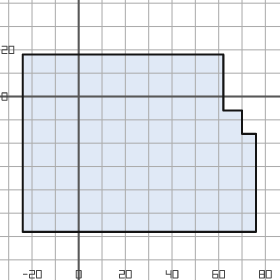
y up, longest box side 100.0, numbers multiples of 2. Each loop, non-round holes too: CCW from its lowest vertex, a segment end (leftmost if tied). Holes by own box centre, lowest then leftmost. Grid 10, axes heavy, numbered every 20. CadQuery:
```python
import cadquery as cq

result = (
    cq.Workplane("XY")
    .moveTo(-24.0, -58.0)
    .lineTo(76.0, -58.0)
    .lineTo(76.0, -16.0)
    .lineTo(70.0, -16.0)
    .lineTo(70.0, -6.0)
    .lineTo(62.0, -6.0)
    .lineTo(62.0, 18.0)
    .lineTo(-24.0, 18.0)
    .close()
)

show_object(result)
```